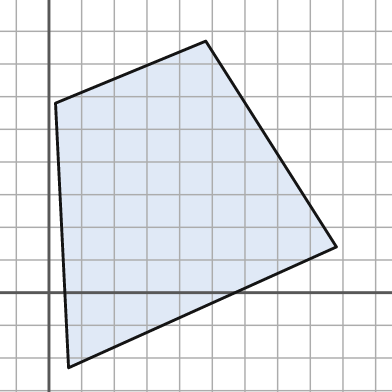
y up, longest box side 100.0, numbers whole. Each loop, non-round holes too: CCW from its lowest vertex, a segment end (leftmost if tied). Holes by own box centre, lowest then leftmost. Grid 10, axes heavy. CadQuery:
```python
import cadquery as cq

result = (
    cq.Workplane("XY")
    .moveTo(6.0, -23.0)
    .lineTo(88.0, 14.0)
    .lineTo(48.0, 77.0)
    .lineTo(2.0, 58.0)
    .close()
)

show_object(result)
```